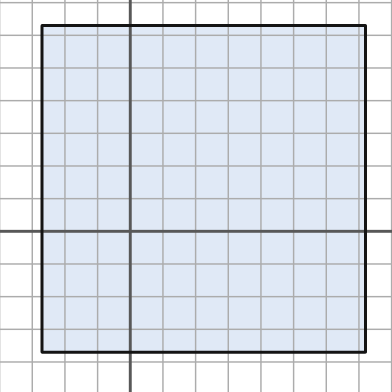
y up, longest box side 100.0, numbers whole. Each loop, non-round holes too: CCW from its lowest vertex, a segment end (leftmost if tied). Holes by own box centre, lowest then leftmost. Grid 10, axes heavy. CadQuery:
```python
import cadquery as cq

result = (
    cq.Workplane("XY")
    .moveTo(-27.0, -37.0)
    .lineTo(72.0, -37.0)
    .lineTo(72.0, 63.0)
    .lineTo(-27.0, 63.0)
    .close()
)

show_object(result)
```